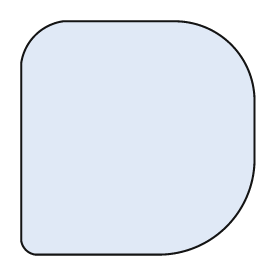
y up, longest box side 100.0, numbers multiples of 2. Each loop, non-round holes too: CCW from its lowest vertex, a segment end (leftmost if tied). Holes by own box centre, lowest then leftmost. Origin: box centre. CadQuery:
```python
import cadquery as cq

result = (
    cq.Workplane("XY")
    .moveTo(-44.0, -50.0)
    .lineTo(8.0, -50.0)
    .threePointArc((38.0, -38.0), (50.0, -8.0))
    .lineTo(50.0, 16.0)
    .threePointArc((40.0, 40.0), (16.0, 50.0))
    .lineTo(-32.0, 50.0)
    .threePointArc((-44.0, 44.0), (-50.0, 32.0))
    .lineTo(-50.0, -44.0)
    .threePointArc((-48.0, -48.0), (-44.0, -50.0))
    .close()
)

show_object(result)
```